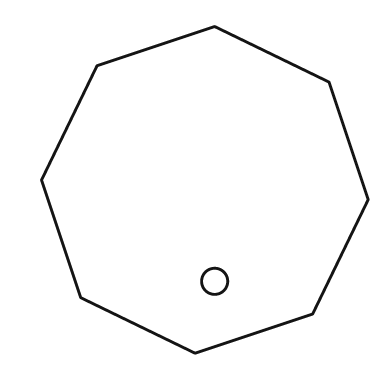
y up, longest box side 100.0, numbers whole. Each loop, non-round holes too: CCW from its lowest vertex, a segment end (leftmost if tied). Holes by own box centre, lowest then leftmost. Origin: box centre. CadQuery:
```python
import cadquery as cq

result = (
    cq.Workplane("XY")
    .moveTo(-3.0, -50.0)
    .lineTo(33.0, -38.0)
    .lineTo(50.0, -3.0)
    .lineTo(38.0, 33.0)
    .lineTo(3.0, 50.0)
    .lineTo(-33.0, 38.0)
    .lineTo(-50.0, 3.0)
    .lineTo(-38.0, -33.0)
    .close()
    .moveTo(3.0, -28.0)
    .circle(4.0)
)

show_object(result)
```